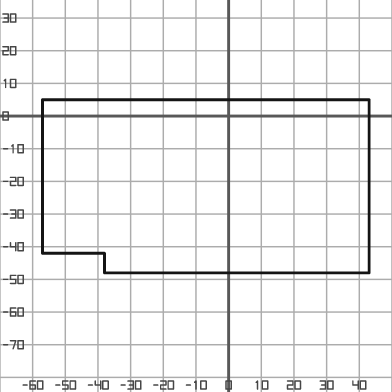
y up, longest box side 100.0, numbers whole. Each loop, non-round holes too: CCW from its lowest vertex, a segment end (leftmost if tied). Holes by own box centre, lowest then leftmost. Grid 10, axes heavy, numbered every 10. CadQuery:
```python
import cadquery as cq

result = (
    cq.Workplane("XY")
    .moveTo(-38.0, -48.0)
    .lineTo(43.0, -48.0)
    .lineTo(43.0, 5.0)
    .lineTo(-57.0, 5.0)
    .lineTo(-57.0, -42.0)
    .lineTo(-38.0, -42.0)
    .close()
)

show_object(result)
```